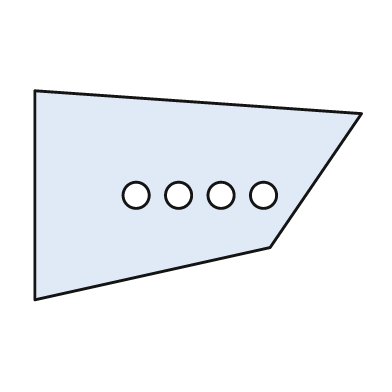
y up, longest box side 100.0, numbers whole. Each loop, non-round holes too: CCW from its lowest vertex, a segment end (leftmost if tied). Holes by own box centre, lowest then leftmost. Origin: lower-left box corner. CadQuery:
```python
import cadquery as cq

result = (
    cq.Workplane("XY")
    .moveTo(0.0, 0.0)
    .lineTo(72.0, 16.0)
    .lineTo(100.0, 57.0)
    .lineTo(0.0, 64.0)
    .close()
    .moveTo(31.0, 32.0)
    .circle(4.0)
    .moveTo(44.0, 32.0)
    .circle(4.0)
    .moveTo(57.0, 32.0)
    .circle(4.0)
    .moveTo(70.0, 32.0)
    .circle(4.0)
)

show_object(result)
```